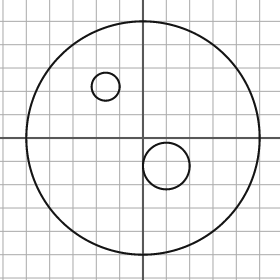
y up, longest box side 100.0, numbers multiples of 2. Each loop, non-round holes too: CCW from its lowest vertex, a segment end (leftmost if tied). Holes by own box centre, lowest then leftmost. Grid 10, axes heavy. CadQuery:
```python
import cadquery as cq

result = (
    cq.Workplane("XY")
    .moveTo(0.0, 0.0)
    .circle(50.0)
    .moveTo(10.0, -12.0)
    .circle(10.0)
    .moveTo(-16.0, 22.0)
    .circle(6.0)
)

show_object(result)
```